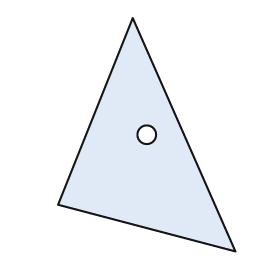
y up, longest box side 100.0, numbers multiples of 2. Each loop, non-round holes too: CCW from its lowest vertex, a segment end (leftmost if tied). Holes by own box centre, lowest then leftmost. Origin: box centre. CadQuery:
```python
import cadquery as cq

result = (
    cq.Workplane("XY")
    .moveTo(38.0, -50.0)
    .lineTo(-6.0, 50.0)
    .lineTo(-38.0, -30.0)
    .close()
    .moveTo(0.0, 0.0)
    .circle(4.0)
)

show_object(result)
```